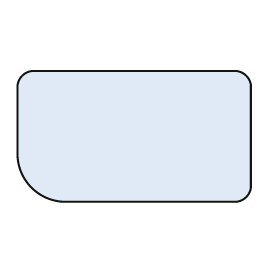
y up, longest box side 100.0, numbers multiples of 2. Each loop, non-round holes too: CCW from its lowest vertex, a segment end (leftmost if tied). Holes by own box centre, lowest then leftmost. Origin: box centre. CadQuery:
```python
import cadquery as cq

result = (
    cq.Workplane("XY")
    .moveTo(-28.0, -28.0)
    .lineTo(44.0, -28.0)
    .threePointArc((48.0, -26.0), (50.0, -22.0))
    .lineTo(50.0, 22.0)
    .threePointArc((48.0, 26.0), (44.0, 28.0))
    .lineTo(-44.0, 28.0)
    .threePointArc((-48.0, 26.0), (-50.0, 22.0))
    .lineTo(-50.0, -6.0)
    .threePointArc((-44.0, -22.0), (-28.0, -28.0))
    .close()
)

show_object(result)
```